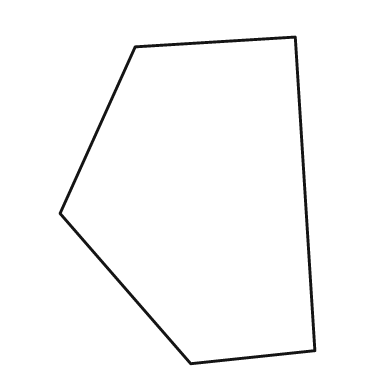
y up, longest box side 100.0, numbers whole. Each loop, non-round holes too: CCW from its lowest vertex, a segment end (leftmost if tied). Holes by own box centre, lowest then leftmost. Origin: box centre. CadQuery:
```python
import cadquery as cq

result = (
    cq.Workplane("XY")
    .moveTo(1.0, -50.0)
    .lineTo(39.0, -46.0)
    .lineTo(33.0, 50.0)
    .lineTo(-16.0, 47.0)
    .lineTo(-39.0, -4.0)
    .close()
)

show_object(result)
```